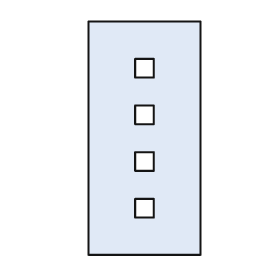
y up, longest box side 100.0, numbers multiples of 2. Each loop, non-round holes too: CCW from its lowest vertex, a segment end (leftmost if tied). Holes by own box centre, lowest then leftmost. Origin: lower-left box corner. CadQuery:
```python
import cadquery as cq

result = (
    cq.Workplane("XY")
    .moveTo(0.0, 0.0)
    .lineTo(48.0, 0.0)
    .lineTo(48.0, 100.0)
    .lineTo(0.0, 100.0)
    .close()
    .moveTo(20.0, 16.0)
    .lineTo(28.0, 16.0)
    .lineTo(28.0, 24.0)
    .lineTo(20.0, 24.0)
    .close()
    .moveTo(20.0, 36.0)
    .lineTo(28.0, 36.0)
    .lineTo(28.0, 44.0)
    .lineTo(20.0, 44.0)
    .close()
    .moveTo(20.0, 56.0)
    .lineTo(28.0, 56.0)
    .lineTo(28.0, 64.0)
    .lineTo(20.0, 64.0)
    .close()
    .moveTo(20.0, 76.0)
    .lineTo(28.0, 76.0)
    .lineTo(28.0, 84.0)
    .lineTo(20.0, 84.0)
    .close()
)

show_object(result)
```